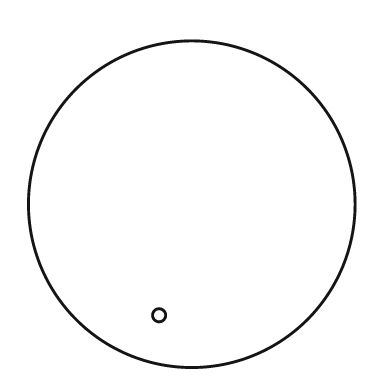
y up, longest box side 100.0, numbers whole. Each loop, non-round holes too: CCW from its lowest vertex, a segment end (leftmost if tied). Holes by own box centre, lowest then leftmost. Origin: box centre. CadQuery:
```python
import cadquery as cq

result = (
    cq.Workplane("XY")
    .moveTo(0.0, 0.0)
    .circle(50.0)
    .moveTo(-10.0, -34.0)
    .circle(2.0)
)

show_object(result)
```